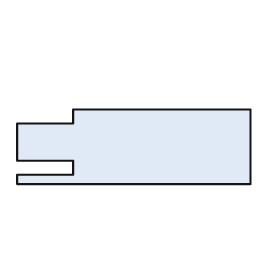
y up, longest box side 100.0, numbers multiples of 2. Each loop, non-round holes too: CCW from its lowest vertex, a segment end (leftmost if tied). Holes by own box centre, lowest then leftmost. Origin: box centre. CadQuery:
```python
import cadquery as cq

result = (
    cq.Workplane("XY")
    .moveTo(-50.0, -16.0)
    .lineTo(50.0, -16.0)
    .lineTo(50.0, 16.0)
    .lineTo(-26.0, 16.0)
    .lineTo(-26.0, 10.0)
    .lineTo(-50.0, 10.0)
    .lineTo(-50.0, -6.0)
    .lineTo(-26.0, -6.0)
    .lineTo(-26.0, -12.0)
    .lineTo(-50.0, -12.0)
    .close()
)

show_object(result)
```